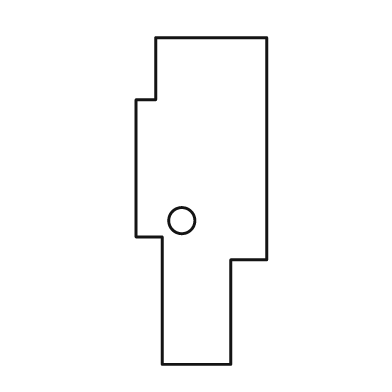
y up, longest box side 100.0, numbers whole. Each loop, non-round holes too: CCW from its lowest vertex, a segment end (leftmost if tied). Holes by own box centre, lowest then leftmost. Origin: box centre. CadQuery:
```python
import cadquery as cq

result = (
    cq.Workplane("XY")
    .moveTo(-12.0, -50.0)
    .lineTo(9.0, -50.0)
    .lineTo(9.0, -18.0)
    .lineTo(20.0, -18.0)
    .lineTo(20.0, 50.0)
    .lineTo(-14.0, 50.0)
    .lineTo(-14.0, 31.0)
    .lineTo(-20.0, 31.0)
    .lineTo(-20.0, -11.0)
    .lineTo(-12.0, -11.0)
    .close()
    .moveTo(-6.0, -6.0)
    .circle(4.0)
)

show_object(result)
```